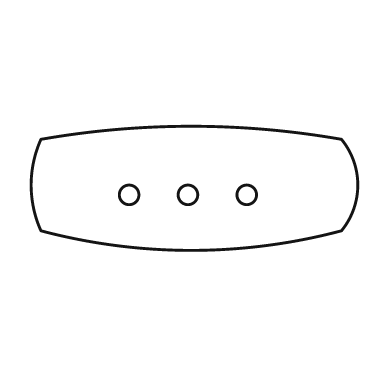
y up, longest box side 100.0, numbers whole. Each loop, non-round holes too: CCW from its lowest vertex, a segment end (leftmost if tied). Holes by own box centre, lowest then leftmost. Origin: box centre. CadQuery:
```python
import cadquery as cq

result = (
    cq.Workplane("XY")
    .moveTo(-47.0, -13.0)
    .threePointArc((-1.0, -19.0), (45.0, -13.0))
    .threePointArc((50.0, 1.0), (45.0, 15.0))
    .threePointArc((-1.0, 19.0), (-47.0, 15.0))
    .threePointArc((-50.0, 1.0), (-47.0, -13.0))
    .close()
    .moveTo(-20.0, -2.0)
    .circle(3.0)
    .moveTo(-2.0, -2.0)
    .circle(3.0)
    .moveTo(16.0, -2.0)
    .circle(3.0)
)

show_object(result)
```